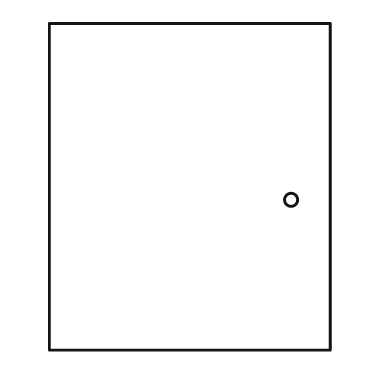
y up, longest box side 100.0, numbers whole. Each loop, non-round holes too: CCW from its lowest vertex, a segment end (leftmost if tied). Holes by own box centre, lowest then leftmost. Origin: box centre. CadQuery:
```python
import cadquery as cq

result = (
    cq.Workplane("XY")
    .moveTo(-43.0, -50.0)
    .lineTo(43.0, -50.0)
    .lineTo(43.0, 50.0)
    .lineTo(-43.0, 50.0)
    .close()
    .moveTo(31.0, -4.0)
    .circle(2.0)
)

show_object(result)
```